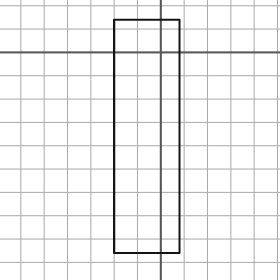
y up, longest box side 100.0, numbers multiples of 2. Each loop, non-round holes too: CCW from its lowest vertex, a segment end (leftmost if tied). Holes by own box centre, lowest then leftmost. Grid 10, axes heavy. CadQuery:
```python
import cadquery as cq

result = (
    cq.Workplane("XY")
    .moveTo(-20.0, -86.0)
    .lineTo(8.0, -86.0)
    .lineTo(8.0, 14.0)
    .lineTo(-20.0, 14.0)
    .close()
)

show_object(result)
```